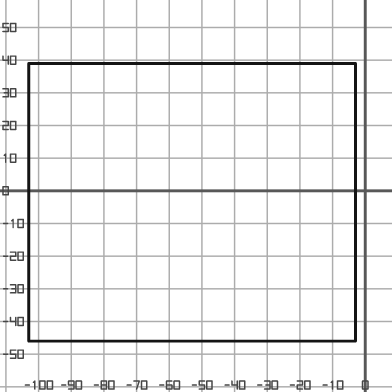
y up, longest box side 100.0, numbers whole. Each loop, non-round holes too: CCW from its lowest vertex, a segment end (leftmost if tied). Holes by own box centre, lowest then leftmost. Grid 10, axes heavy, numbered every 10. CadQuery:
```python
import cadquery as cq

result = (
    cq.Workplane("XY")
    .moveTo(-103.0, -46.0)
    .lineTo(-3.0, -46.0)
    .lineTo(-3.0, 39.0)
    .lineTo(-103.0, 39.0)
    .close()
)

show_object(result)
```